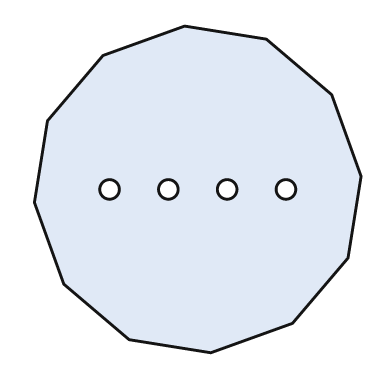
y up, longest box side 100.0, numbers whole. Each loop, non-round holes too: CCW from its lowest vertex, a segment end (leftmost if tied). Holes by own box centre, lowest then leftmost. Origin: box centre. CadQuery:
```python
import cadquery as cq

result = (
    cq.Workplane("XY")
    .moveTo(4.0, -50.0)
    .lineTo(29.0, -41.0)
    .lineTo(46.0, -21.0)
    .lineTo(50.0, 4.0)
    .lineTo(41.0, 29.0)
    .lineTo(21.0, 46.0)
    .lineTo(-4.0, 50.0)
    .lineTo(-29.0, 41.0)
    .lineTo(-46.0, 21.0)
    .lineTo(-50.0, -4.0)
    .lineTo(-41.0, -29.0)
    .lineTo(-21.0, -46.0)
    .close()
    .moveTo(-27.0, 0.0)
    .circle(3.0)
    .moveTo(-9.0, 0.0)
    .circle(3.0)
    .moveTo(9.0, 0.0)
    .circle(3.0)
    .moveTo(27.0, 0.0)
    .circle(3.0)
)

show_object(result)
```